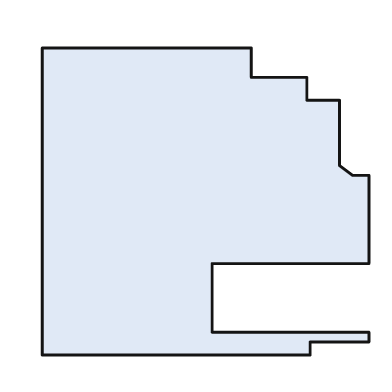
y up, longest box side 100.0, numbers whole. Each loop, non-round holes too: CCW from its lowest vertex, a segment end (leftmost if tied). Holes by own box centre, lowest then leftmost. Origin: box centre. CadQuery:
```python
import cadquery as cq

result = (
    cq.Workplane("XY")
    .moveTo(-50.0, -47.0)
    .lineTo(32.0, -47.0)
    .lineTo(32.0, -43.0)
    .lineTo(50.0, -43.0)
    .lineTo(50.0, -40.0)
    .lineTo(2.0, -40.0)
    .lineTo(2.0, -19.0)
    .lineTo(50.0, -19.0)
    .lineTo(50.0, 8.0)
    .lineTo(45.0, 8.0)
    .lineTo(41.0, 11.0)
    .lineTo(41.0, 31.0)
    .lineTo(31.0, 31.0)
    .lineTo(31.0, 38.0)
    .lineTo(14.0, 38.0)
    .lineTo(14.0, 47.0)
    .lineTo(-50.0, 47.0)
    .close()
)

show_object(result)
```